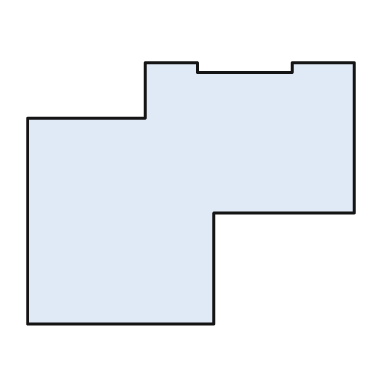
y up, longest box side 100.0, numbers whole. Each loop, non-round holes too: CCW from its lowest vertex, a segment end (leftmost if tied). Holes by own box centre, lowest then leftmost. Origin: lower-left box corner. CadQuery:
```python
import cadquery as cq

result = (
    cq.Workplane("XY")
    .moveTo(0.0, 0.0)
    .lineTo(57.0, 0.0)
    .lineTo(57.0, 34.0)
    .lineTo(100.0, 34.0)
    .lineTo(100.0, 80.0)
    .lineTo(81.0, 80.0)
    .lineTo(81.0, 77.0)
    .lineTo(52.0, 77.0)
    .lineTo(52.0, 80.0)
    .lineTo(36.0, 80.0)
    .lineTo(36.0, 63.0)
    .lineTo(0.0, 63.0)
    .close()
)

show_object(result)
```